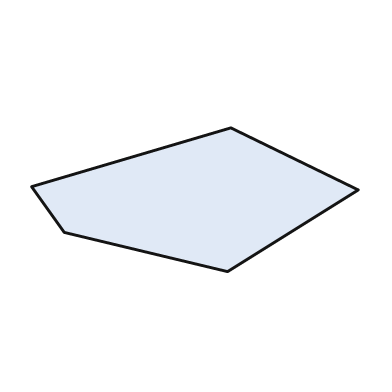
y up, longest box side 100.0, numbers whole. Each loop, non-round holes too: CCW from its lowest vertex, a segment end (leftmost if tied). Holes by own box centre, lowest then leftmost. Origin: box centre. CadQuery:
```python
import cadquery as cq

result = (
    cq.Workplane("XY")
    .moveTo(10.0, -22.0)
    .lineTo(50.0, 3.0)
    .lineTo(11.0, 22.0)
    .lineTo(-50.0, 4.0)
    .lineTo(-40.0, -10.0)
    .close()
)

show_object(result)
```